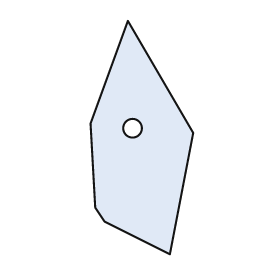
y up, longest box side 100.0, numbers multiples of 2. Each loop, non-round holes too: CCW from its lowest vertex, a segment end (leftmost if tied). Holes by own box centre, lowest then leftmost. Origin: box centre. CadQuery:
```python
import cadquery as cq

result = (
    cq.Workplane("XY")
    .moveTo(12.0, -50.0)
    .lineTo(22.0, 2.0)
    .lineTo(-6.0, 50.0)
    .lineTo(-22.0, 6.0)
    .lineTo(-20.0, -30.0)
    .lineTo(-16.0, -36.0)
    .close()
    .moveTo(-4.0, 4.0)
    .circle(4.0)
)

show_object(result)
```